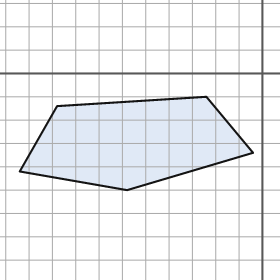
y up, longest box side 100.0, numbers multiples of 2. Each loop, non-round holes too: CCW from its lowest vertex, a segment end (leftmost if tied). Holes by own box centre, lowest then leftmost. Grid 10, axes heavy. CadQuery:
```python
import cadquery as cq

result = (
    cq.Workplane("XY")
    .moveTo(-58.0, -50.0)
    .lineTo(-4.0, -34.0)
    .lineTo(-24.0, -10.0)
    .lineTo(-88.0, -14.0)
    .lineTo(-104.0, -42.0)
    .close()
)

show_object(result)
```